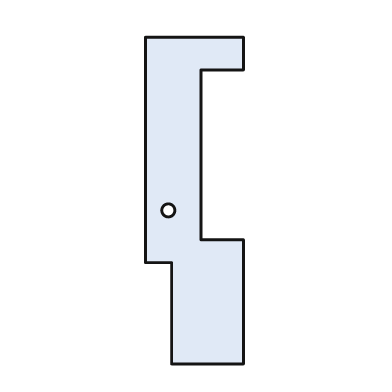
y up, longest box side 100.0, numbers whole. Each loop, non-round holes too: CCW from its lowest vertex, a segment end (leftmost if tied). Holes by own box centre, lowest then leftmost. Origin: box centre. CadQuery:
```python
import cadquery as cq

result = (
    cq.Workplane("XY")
    .moveTo(-7.0, -50.0)
    .lineTo(15.0, -50.0)
    .lineTo(15.0, -12.0)
    .lineTo(2.0, -12.0)
    .lineTo(2.0, 40.0)
    .lineTo(15.0, 40.0)
    .lineTo(15.0, 50.0)
    .lineTo(-15.0, 50.0)
    .lineTo(-15.0, -19.0)
    .lineTo(-7.0, -19.0)
    .close()
    .moveTo(-8.0, -3.0)
    .circle(2.0)
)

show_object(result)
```